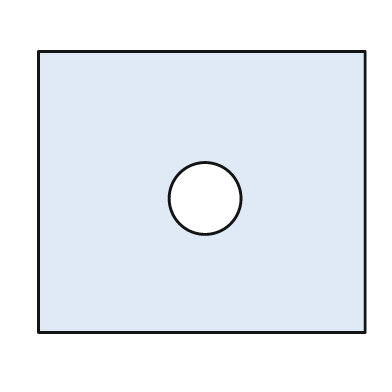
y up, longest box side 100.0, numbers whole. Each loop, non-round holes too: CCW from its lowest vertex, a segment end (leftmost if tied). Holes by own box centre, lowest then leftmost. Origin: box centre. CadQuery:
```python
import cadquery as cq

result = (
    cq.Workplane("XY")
    .moveTo(-50.0, -43.0)
    .lineTo(50.0, -43.0)
    .lineTo(50.0, 43.0)
    .lineTo(-50.0, 43.0)
    .close()
    .moveTo(1.0, -2.0)
    .circle(11.0)
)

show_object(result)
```